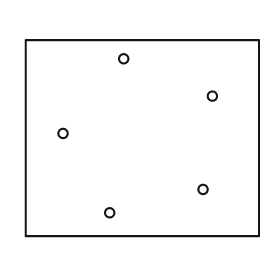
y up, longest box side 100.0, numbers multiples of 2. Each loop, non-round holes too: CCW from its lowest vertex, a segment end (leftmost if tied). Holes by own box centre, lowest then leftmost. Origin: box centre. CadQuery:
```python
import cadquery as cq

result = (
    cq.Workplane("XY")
    .moveTo(-50.0, -42.0)
    .lineTo(50.0, -42.0)
    .lineTo(50.0, 42.0)
    .lineTo(-50.0, 42.0)
    .close()
    .moveTo(-14.0, -32.0)
    .circle(2.0)
    .moveTo(26.0, -22.0)
    .circle(2.0)
    .moveTo(-34.0, 2.0)
    .circle(2.0)
    .moveTo(30.0, 18.0)
    .circle(2.0)
    .moveTo(-8.0, 34.0)
    .circle(2.0)
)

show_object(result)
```